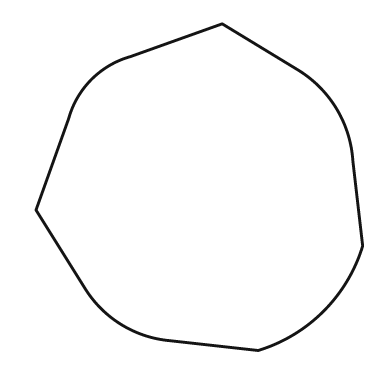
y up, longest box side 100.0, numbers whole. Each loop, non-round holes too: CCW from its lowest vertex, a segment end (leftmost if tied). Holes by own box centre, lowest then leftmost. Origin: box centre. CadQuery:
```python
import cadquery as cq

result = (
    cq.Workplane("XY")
    .moveTo(18.0, -50.0)
    .threePointArc((38.0, -38.0), (50.0, -18.0))
    .lineTo(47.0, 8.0)
    .threePointArc((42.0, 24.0), (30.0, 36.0))
    .lineTo(7.0, 50.0)
    .lineTo(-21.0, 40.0)
    .threePointArc((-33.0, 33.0), (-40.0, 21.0))
    .lineTo(-50.0, -7.0)
    .lineTo(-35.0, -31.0)
    .threePointArc((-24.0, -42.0), (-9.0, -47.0))
    .close()
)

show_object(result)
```